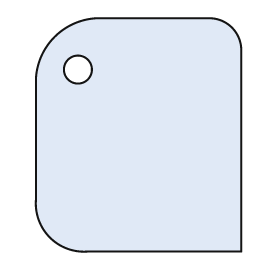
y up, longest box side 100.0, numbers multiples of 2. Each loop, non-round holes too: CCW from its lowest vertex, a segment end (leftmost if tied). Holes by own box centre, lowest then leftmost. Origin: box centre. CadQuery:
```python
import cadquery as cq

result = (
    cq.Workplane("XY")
    .moveTo(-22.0, -50.0)
    .lineTo(44.0, -50.0)
    .lineTo(44.0, 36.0)
    .threePointArc((40.0, 46.0), (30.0, 50.0))
    .lineTo(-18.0, 50.0)
    .threePointArc((-36.0, 42.0), (-44.0, 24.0))
    .lineTo(-44.0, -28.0)
    .threePointArc((-38.0, -44.0), (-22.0, -50.0))
    .close()
    .moveTo(-26.0, 28.0)
    .circle(6.0)
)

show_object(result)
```